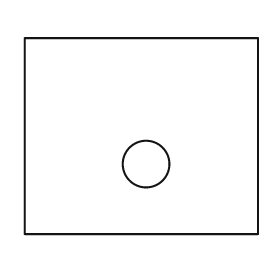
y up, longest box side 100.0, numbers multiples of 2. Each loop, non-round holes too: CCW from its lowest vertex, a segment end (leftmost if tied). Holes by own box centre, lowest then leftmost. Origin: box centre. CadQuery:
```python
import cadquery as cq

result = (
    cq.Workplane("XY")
    .moveTo(-50.0, -42.0)
    .lineTo(50.0, -42.0)
    .lineTo(50.0, 42.0)
    .lineTo(-50.0, 42.0)
    .close()
    .moveTo(2.0, -12.0)
    .circle(10.0)
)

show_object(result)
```